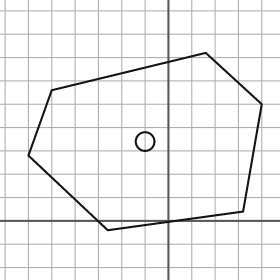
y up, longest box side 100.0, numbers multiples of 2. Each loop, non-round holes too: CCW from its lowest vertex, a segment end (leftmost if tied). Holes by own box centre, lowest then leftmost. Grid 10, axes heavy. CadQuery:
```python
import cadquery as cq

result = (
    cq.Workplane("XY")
    .moveTo(-26.0, -4.0)
    .lineTo(32.0, 4.0)
    .lineTo(40.0, 50.0)
    .lineTo(16.0, 72.0)
    .lineTo(-50.0, 56.0)
    .lineTo(-60.0, 28.0)
    .close()
    .moveTo(-10.0, 34.0)
    .circle(4.0)
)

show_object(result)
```